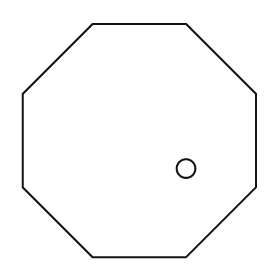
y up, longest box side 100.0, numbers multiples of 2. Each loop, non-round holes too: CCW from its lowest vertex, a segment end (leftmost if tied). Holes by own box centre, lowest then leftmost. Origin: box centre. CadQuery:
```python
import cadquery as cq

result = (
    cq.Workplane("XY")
    .moveTo(-20.0, -50.0)
    .lineTo(20.0, -50.0)
    .lineTo(50.0, -20.0)
    .lineTo(50.0, 20.0)
    .lineTo(20.0, 50.0)
    .lineTo(-20.0, 50.0)
    .lineTo(-50.0, 20.0)
    .lineTo(-50.0, -20.0)
    .close()
    .moveTo(20.0, -12.0)
    .circle(4.0)
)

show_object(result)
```